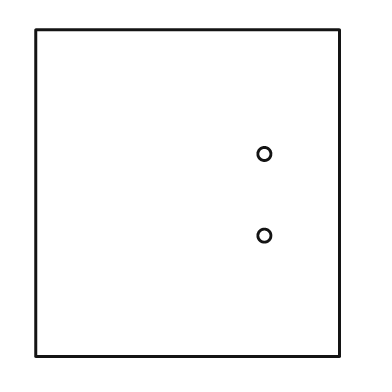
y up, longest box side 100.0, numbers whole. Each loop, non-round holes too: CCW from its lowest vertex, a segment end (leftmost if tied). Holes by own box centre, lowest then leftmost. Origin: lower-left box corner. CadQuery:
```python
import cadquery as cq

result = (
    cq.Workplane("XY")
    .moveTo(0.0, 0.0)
    .lineTo(93.0, 0.0)
    .lineTo(93.0, 100.0)
    .lineTo(0.0, 100.0)
    .close()
    .moveTo(70.0, 37.0)
    .circle(2.0)
    .moveTo(70.0, 62.0)
    .circle(2.0)
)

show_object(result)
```